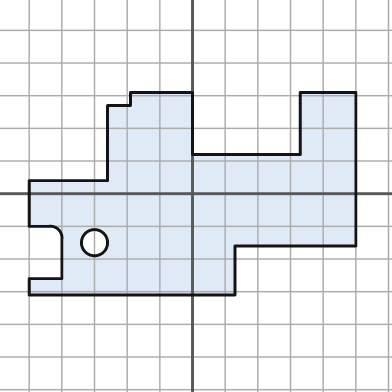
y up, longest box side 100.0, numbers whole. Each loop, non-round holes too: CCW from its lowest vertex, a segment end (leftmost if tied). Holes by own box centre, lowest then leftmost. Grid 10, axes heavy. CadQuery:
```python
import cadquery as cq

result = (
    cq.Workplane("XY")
    .moveTo(-50.0, -31.0)
    .lineTo(13.0, -31.0)
    .lineTo(13.0, -16.0)
    .lineTo(50.0, -16.0)
    .lineTo(50.0, 31.0)
    .lineTo(33.0, 31.0)
    .lineTo(33.0, 12.0)
    .lineTo(0.0, 12.0)
    .lineTo(0.0, 31.0)
    .lineTo(-19.0, 31.0)
    .lineTo(-19.0, 27.0)
    .lineTo(-26.0, 27.0)
    .lineTo(-26.0, 4.0)
    .lineTo(-50.0, 4.0)
    .lineTo(-50.0, -10.0)
    .lineTo(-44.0, -10.0)
    .threePointArc((-41.0, -11.0), (-40.0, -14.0))
    .lineTo(-40.0, -26.0)
    .lineTo(-50.0, -26.0)
    .close()
    .moveTo(-30.0, -15.0)
    .circle(4.0)
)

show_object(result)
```